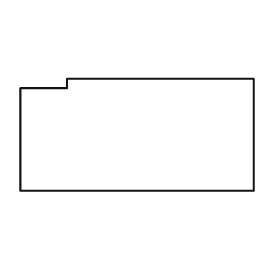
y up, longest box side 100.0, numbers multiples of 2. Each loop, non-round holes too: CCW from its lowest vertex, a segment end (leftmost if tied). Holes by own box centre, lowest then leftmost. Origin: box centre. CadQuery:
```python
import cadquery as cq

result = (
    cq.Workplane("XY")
    .moveTo(-50.0, -24.0)
    .lineTo(50.0, -24.0)
    .lineTo(50.0, 24.0)
    .lineTo(-30.0, 24.0)
    .lineTo(-30.0, 20.0)
    .lineTo(-50.0, 20.0)
    .close()
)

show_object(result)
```